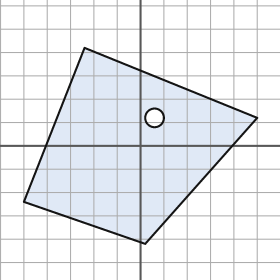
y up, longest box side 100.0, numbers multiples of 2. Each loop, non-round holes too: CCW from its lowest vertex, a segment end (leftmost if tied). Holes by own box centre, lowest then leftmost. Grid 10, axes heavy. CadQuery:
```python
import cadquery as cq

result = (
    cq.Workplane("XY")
    .moveTo(2.0, -42.0)
    .lineTo(50.0, 12.0)
    .lineTo(-24.0, 42.0)
    .lineTo(-50.0, -24.0)
    .close()
    .moveTo(6.0, 12.0)
    .circle(4.0)
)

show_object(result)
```